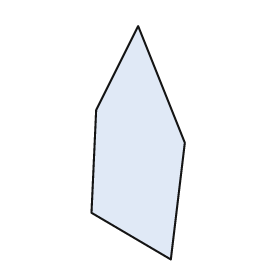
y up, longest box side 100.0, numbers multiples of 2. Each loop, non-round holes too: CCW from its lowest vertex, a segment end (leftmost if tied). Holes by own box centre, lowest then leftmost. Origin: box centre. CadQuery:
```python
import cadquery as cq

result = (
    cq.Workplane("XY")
    .moveTo(14.0, -50.0)
    .lineTo(20.0, 0.0)
    .lineTo(0.0, 50.0)
    .lineTo(-18.0, 14.0)
    .lineTo(-20.0, -30.0)
    .close()
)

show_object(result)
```